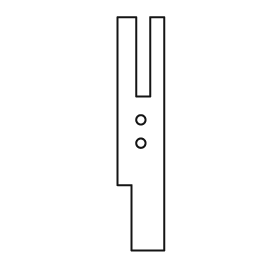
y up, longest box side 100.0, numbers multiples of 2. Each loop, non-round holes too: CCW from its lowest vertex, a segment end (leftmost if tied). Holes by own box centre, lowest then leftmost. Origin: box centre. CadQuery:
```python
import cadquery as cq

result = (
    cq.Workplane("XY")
    .moveTo(-4.0, -50.0)
    .lineTo(10.0, -50.0)
    .lineTo(10.0, 50.0)
    .lineTo(4.0, 50.0)
    .lineTo(4.0, 16.0)
    .lineTo(-2.0, 16.0)
    .lineTo(-2.0, 50.0)
    .lineTo(-10.0, 50.0)
    .lineTo(-10.0, -22.0)
    .lineTo(-4.0, -22.0)
    .close()
    .moveTo(0.0, -4.0)
    .circle(2.0)
    .moveTo(0.0, 6.0)
    .circle(2.0)
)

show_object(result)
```